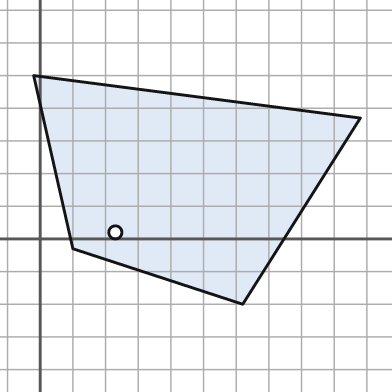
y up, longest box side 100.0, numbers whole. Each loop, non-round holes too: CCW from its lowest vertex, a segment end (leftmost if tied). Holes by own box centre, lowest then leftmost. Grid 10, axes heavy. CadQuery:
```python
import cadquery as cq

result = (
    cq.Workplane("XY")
    .moveTo(62.0, -20.0)
    .lineTo(98.0, 37.0)
    .lineTo(-2.0, 50.0)
    .lineTo(10.0, -3.0)
    .close()
    .moveTo(23.0, 2.0)
    .circle(2.0)
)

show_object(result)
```